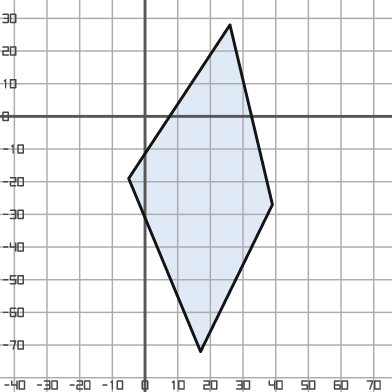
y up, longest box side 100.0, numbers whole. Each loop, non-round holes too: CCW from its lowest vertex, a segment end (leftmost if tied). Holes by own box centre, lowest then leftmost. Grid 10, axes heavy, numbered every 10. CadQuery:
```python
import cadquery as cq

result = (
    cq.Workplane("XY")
    .moveTo(17.0, -72.0)
    .lineTo(39.0, -27.0)
    .lineTo(26.0, 28.0)
    .lineTo(-5.0, -19.0)
    .close()
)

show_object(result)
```